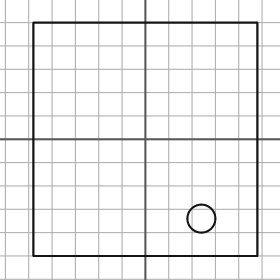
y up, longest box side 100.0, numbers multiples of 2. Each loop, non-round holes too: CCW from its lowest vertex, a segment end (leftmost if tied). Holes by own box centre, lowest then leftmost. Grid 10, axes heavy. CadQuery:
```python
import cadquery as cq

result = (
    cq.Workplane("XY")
    .moveTo(-48.0, -50.0)
    .lineTo(48.0, -50.0)
    .lineTo(48.0, 50.0)
    .lineTo(-48.0, 50.0)
    .close()
    .moveTo(24.0, -34.0)
    .circle(6.0)
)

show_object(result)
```